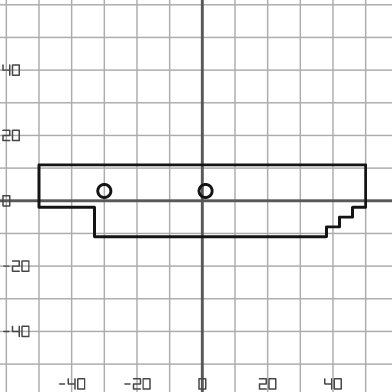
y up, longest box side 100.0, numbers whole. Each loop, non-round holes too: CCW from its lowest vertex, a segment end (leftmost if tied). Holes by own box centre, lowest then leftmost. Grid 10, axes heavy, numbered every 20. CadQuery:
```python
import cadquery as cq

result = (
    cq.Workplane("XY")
    .moveTo(-33.0, -11.0)
    .lineTo(38.0, -11.0)
    .lineTo(38.0, -8.0)
    .lineTo(42.0, -8.0)
    .lineTo(42.0, -5.0)
    .lineTo(46.0, -5.0)
    .lineTo(46.0, -2.0)
    .lineTo(50.0, -2.0)
    .lineTo(50.0, 11.0)
    .lineTo(-50.0, 11.0)
    .lineTo(-50.0, -2.0)
    .lineTo(-33.0, -2.0)
    .close()
    .moveTo(-30.0, 3.0)
    .circle(2.0)
    .moveTo(1.0, 3.0)
    .circle(2.0)
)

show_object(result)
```